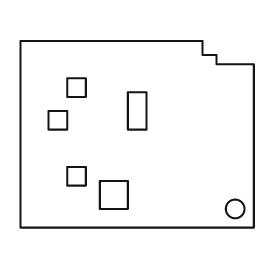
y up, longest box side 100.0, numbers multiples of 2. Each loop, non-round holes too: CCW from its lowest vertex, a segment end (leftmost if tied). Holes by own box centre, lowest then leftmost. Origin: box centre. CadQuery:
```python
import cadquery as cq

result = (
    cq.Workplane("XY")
    .moveTo(-50.0, -40.0)
    .lineTo(50.0, -40.0)
    .lineTo(50.0, 30.0)
    .lineTo(34.0, 30.0)
    .lineTo(34.0, 34.0)
    .lineTo(28.0, 34.0)
    .lineTo(28.0, 40.0)
    .lineTo(-50.0, 40.0)
    .close()
    .moveTo(42.0, -32.0)
    .circle(4.0)
    .moveTo(-16.0, -32.0)
    .lineTo(-4.0, -32.0)
    .lineTo(-4.0, -20.0)
    .lineTo(-16.0, -20.0)
    .close()
    .moveTo(-30.0, -22.0)
    .lineTo(-22.0, -22.0)
    .lineTo(-22.0, -14.0)
    .lineTo(-30.0, -14.0)
    .close()
    .moveTo(-38.0, 2.0)
    .lineTo(-30.0, 2.0)
    .lineTo(-30.0, 10.0)
    .lineTo(-38.0, 10.0)
    .close()
    .moveTo(-4.0, 2.0)
    .lineTo(4.0, 2.0)
    .lineTo(4.0, 18.0)
    .lineTo(-4.0, 18.0)
    .close()
    .moveTo(-30.0, 16.0)
    .lineTo(-22.0, 16.0)
    .lineTo(-22.0, 24.0)
    .lineTo(-30.0, 24.0)
    .close()
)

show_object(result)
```